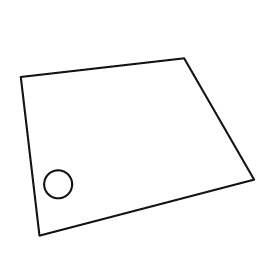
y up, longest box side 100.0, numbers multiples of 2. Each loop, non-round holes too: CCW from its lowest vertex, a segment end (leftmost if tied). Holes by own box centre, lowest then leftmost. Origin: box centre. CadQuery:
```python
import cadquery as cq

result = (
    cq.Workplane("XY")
    .moveTo(-42.0, -38.0)
    .lineTo(50.0, -14.0)
    .lineTo(20.0, 38.0)
    .lineTo(-50.0, 30.0)
    .close()
    .moveTo(-34.0, -16.0)
    .circle(6.0)
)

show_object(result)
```